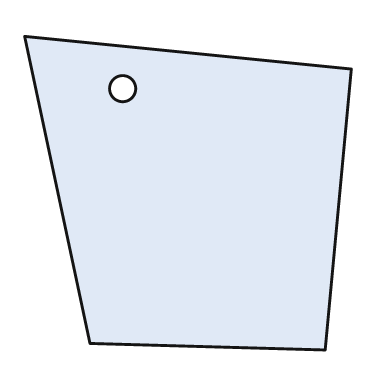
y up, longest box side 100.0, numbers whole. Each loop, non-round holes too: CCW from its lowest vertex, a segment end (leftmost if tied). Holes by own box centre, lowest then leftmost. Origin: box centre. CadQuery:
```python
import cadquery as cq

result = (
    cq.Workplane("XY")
    .moveTo(42.0, -48.0)
    .lineTo(50.0, 38.0)
    .lineTo(-50.0, 48.0)
    .lineTo(-30.0, -46.0)
    .close()
    .moveTo(-20.0, 32.0)
    .circle(4.0)
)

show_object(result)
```